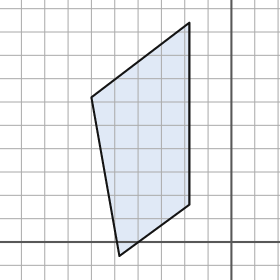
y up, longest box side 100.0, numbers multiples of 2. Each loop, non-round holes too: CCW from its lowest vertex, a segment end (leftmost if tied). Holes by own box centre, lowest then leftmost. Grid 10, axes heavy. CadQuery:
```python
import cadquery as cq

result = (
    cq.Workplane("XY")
    .moveTo(-48.0, -6.0)
    .lineTo(-18.0, 16.0)
    .lineTo(-18.0, 94.0)
    .lineTo(-60.0, 62.0)
    .close()
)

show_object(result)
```